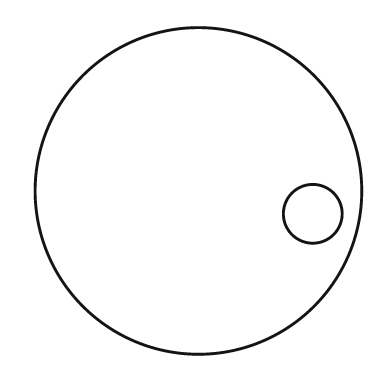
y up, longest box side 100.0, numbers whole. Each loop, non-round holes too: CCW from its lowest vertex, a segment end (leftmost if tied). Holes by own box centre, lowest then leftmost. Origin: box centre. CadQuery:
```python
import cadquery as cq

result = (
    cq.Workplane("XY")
    .moveTo(0.0, 0.0)
    .circle(50.0)
    .moveTo(35.0, -7.0)
    .circle(9.0)
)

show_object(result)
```